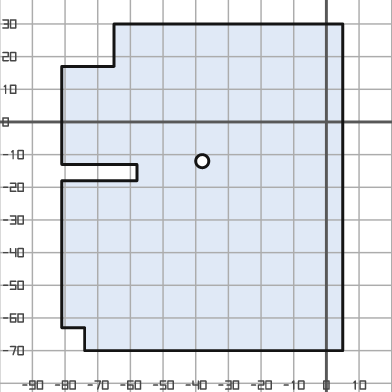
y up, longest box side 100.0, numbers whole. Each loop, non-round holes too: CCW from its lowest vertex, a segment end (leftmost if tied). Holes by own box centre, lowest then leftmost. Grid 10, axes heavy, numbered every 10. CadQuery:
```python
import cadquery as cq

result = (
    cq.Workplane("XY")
    .moveTo(-74.0, -70.0)
    .lineTo(5.0, -70.0)
    .lineTo(5.0, 30.0)
    .lineTo(-65.0, 30.0)
    .lineTo(-65.0, 17.0)
    .lineTo(-81.0, 17.0)
    .lineTo(-81.0, -13.0)
    .lineTo(-58.0, -13.0)
    .lineTo(-58.0, -18.0)
    .lineTo(-81.0, -18.0)
    .lineTo(-81.0, -63.0)
    .lineTo(-74.0, -63.0)
    .close()
    .moveTo(-38.0, -12.0)
    .circle(2.0)
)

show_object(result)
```